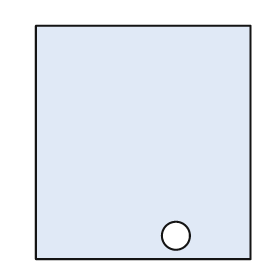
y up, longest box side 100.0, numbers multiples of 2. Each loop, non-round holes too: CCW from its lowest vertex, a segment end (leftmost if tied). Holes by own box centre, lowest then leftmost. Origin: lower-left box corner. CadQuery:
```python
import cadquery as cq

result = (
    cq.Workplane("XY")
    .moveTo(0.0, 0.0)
    .lineTo(92.0, 0.0)
    .lineTo(92.0, 100.0)
    .lineTo(0.0, 100.0)
    .close()
    .moveTo(60.0, 10.0)
    .circle(6.0)
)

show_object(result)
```